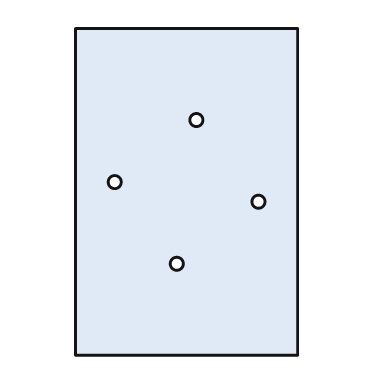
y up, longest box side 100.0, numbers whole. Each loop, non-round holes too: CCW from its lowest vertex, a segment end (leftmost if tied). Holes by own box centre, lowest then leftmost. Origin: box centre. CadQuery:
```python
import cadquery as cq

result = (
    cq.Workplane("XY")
    .moveTo(-34.0, -50.0)
    .lineTo(34.0, -50.0)
    .lineTo(34.0, 50.0)
    .lineTo(-34.0, 50.0)
    .close()
    .moveTo(-3.0, -22.0)
    .circle(2.0)
    .moveTo(22.0, -3.0)
    .circle(2.0)
    .moveTo(-22.0, 3.0)
    .circle(2.0)
    .moveTo(3.0, 22.0)
    .circle(2.0)
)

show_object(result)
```